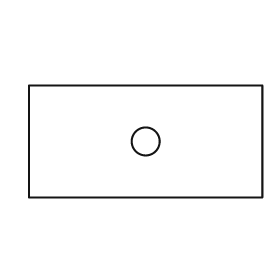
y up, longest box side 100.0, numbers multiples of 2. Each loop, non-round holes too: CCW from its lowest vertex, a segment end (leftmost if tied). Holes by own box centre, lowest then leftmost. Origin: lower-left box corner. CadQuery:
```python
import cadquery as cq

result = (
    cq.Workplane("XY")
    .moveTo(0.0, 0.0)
    .lineTo(100.0, 0.0)
    .lineTo(100.0, 48.0)
    .lineTo(0.0, 48.0)
    .close()
    .moveTo(50.0, 24.0)
    .circle(6.0)
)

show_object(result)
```